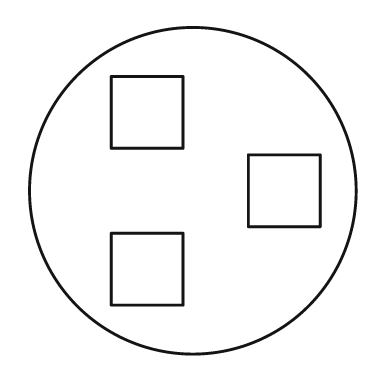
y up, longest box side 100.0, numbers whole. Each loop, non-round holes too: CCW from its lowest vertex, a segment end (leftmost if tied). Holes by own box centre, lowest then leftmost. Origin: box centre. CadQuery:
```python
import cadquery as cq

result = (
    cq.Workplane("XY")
    .moveTo(0.0, 0.0)
    .circle(50.0)
    .moveTo(-25.0, -35.0)
    .lineTo(-3.0, -35.0)
    .lineTo(-3.0, -13.0)
    .lineTo(-25.0, -13.0)
    .close()
    .moveTo(17.0, -11.0)
    .lineTo(39.0, -11.0)
    .lineTo(39.0, 11.0)
    .lineTo(17.0, 11.0)
    .close()
    .moveTo(-25.0, 13.0)
    .lineTo(-3.0, 13.0)
    .lineTo(-3.0, 35.0)
    .lineTo(-25.0, 35.0)
    .close()
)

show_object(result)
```